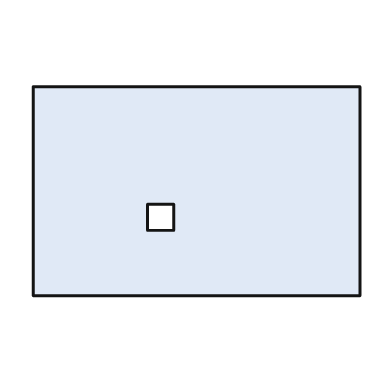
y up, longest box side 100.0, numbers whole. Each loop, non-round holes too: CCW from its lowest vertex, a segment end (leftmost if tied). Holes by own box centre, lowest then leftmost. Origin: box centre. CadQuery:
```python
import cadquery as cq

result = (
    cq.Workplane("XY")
    .moveTo(-50.0, -32.0)
    .lineTo(50.0, -32.0)
    .lineTo(50.0, 32.0)
    .lineTo(-50.0, 32.0)
    .close()
    .moveTo(-15.0, -12.0)
    .lineTo(-7.0, -12.0)
    .lineTo(-7.0, -4.0)
    .lineTo(-15.0, -4.0)
    .close()
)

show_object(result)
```